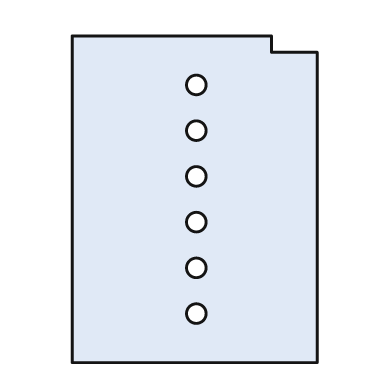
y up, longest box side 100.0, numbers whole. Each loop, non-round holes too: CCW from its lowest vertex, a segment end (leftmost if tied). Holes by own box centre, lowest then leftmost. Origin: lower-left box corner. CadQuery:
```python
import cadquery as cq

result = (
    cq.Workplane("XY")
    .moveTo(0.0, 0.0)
    .lineTo(75.0, 0.0)
    .lineTo(75.0, 95.0)
    .lineTo(61.0, 95.0)
    .lineTo(61.0, 100.0)
    .lineTo(0.0, 100.0)
    .close()
    .moveTo(38.0, 15.0)
    .circle(3.0)
    .moveTo(38.0, 29.0)
    .circle(3.0)
    .moveTo(38.0, 43.0)
    .circle(3.0)
    .moveTo(38.0, 57.0)
    .circle(3.0)
    .moveTo(38.0, 71.0)
    .circle(3.0)
    .moveTo(38.0, 85.0)
    .circle(3.0)
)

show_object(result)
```